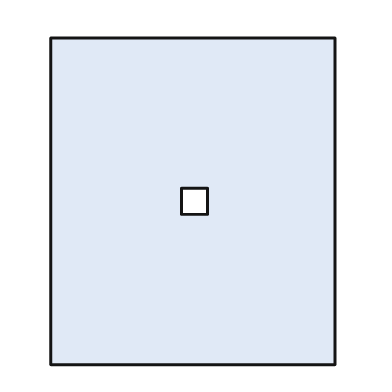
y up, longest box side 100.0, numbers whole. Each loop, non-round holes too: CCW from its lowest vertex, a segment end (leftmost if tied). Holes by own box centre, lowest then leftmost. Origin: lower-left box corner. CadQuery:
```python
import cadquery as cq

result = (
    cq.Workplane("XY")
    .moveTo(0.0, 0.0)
    .lineTo(87.0, 0.0)
    .lineTo(87.0, 100.0)
    .lineTo(0.0, 100.0)
    .close()
    .moveTo(40.0, 46.0)
    .lineTo(48.0, 46.0)
    .lineTo(48.0, 54.0)
    .lineTo(40.0, 54.0)
    .close()
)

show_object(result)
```